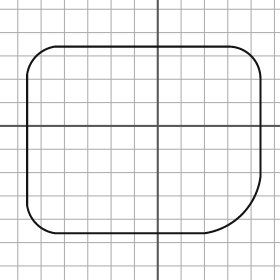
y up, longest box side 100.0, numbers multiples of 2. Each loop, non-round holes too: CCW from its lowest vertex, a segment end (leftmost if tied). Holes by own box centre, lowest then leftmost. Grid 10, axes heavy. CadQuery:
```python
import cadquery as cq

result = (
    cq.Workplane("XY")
    .moveTo(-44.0, -46.0)
    .lineTo(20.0, -46.0)
    .threePointArc((36.0, -38.0), (44.0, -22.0))
    .lineTo(44.0, 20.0)
    .threePointArc((40.0, 30.0), (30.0, 34.0))
    .lineTo(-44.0, 34.0)
    .threePointArc((-52.0, 30.0), (-56.0, 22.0))
    .lineTo(-56.0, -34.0)
    .threePointArc((-52.0, -42.0), (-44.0, -46.0))
    .close()
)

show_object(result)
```